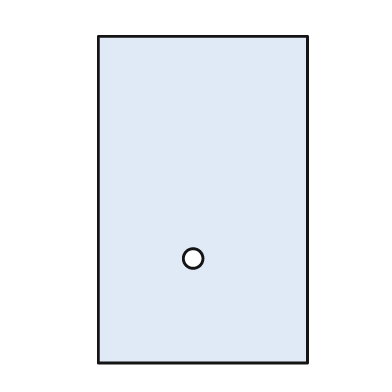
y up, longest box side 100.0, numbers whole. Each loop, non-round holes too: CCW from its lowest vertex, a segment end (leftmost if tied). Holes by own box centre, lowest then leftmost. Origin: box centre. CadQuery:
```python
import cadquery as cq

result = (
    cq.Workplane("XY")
    .moveTo(-32.0, -50.0)
    .lineTo(32.0, -50.0)
    .lineTo(32.0, 50.0)
    .lineTo(-32.0, 50.0)
    .close()
    .moveTo(-3.0, -18.0)
    .circle(3.0)
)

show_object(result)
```